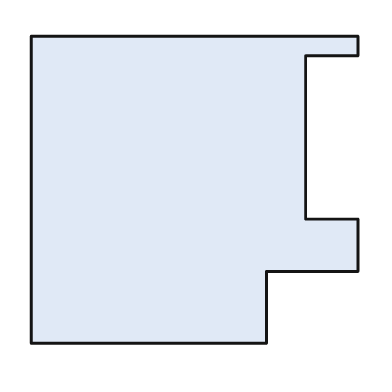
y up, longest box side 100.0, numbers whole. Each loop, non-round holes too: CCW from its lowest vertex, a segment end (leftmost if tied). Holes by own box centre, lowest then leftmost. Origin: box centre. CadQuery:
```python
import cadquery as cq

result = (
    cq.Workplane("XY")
    .moveTo(-50.0, -47.0)
    .lineTo(22.0, -47.0)
    .lineTo(22.0, -25.0)
    .lineTo(50.0, -25.0)
    .lineTo(50.0, -9.0)
    .lineTo(34.0, -9.0)
    .lineTo(34.0, 41.0)
    .lineTo(50.0, 41.0)
    .lineTo(50.0, 47.0)
    .lineTo(-50.0, 47.0)
    .close()
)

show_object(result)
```